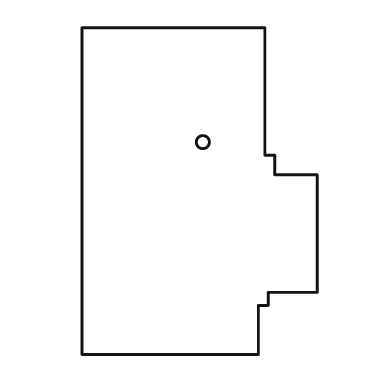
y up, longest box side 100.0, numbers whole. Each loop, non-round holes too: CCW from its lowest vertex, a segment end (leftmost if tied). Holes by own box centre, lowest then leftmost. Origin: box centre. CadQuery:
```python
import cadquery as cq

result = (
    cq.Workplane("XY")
    .moveTo(-36.0, -50.0)
    .lineTo(18.0, -50.0)
    .lineTo(18.0, -35.0)
    .lineTo(21.0, -35.0)
    .lineTo(21.0, -31.0)
    .lineTo(36.0, -31.0)
    .lineTo(36.0, 5.0)
    .lineTo(23.0, 5.0)
    .lineTo(23.0, 11.0)
    .lineTo(20.0, 11.0)
    .lineTo(20.0, 50.0)
    .lineTo(-36.0, 50.0)
    .close()
    .moveTo(1.0, 15.0)
    .circle(2.0)
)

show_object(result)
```